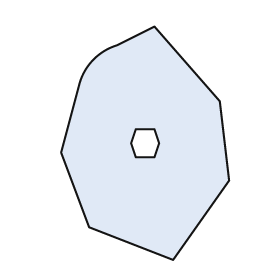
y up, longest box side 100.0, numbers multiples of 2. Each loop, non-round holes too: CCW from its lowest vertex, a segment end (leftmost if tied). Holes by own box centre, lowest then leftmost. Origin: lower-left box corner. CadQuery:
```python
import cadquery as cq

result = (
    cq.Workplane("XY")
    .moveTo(48.0, 0.0)
    .lineTo(72.0, 34.0)
    .lineTo(68.0, 68.0)
    .lineTo(40.0, 100.0)
    .lineTo(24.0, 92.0)
    .threePointArc((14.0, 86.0), (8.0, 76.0))
    .lineTo(0.0, 46.0)
    .lineTo(12.0, 14.0)
    .close()
    .moveTo(32.0, 44.0)
    .lineTo(40.0, 44.0)
    .lineTo(42.0, 50.0)
    .lineTo(40.0, 56.0)
    .lineTo(32.0, 56.0)
    .lineTo(30.0, 50.0)
    .close()
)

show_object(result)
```